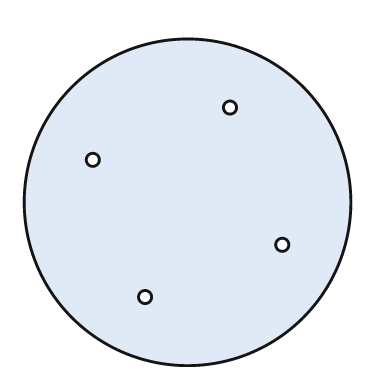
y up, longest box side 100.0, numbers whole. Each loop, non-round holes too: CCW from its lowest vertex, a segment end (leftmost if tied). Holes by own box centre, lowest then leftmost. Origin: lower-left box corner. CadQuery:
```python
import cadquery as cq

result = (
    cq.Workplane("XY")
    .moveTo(50.0, 50.0)
    .circle(50.0)
    .moveTo(37.0, 21.0)
    .circle(2.0)
    .moveTo(79.0, 37.0)
    .circle(2.0)
    .moveTo(21.0, 63.0)
    .circle(2.0)
    .moveTo(63.0, 79.0)
    .circle(2.0)
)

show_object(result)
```